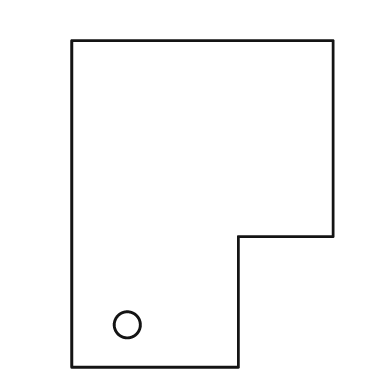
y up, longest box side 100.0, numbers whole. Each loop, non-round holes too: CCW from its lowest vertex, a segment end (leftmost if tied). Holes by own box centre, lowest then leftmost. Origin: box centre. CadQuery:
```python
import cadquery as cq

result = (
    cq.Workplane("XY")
    .moveTo(-40.0, -50.0)
    .lineTo(11.0, -50.0)
    .lineTo(11.0, -10.0)
    .lineTo(40.0, -10.0)
    .lineTo(40.0, 50.0)
    .lineTo(-40.0, 50.0)
    .close()
    .moveTo(-23.0, -37.0)
    .circle(4.0)
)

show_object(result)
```